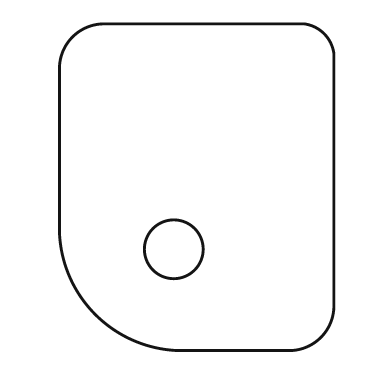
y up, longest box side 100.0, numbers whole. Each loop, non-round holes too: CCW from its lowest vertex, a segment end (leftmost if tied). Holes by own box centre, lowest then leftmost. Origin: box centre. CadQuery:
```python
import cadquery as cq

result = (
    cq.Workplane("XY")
    .moveTo(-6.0, -50.0)
    .lineTo(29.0, -50.0)
    .threePointArc((38.0, -46.0), (42.0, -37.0))
    .lineTo(42.0, 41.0)
    .threePointArc((39.0, 47.0), (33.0, 50.0))
    .lineTo(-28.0, 50.0)
    .threePointArc((-38.0, 46.0), (-42.0, 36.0))
    .lineTo(-42.0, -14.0)
    .threePointArc((-31.0, -39.0), (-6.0, -50.0))
    .close()
    .moveTo(-7.0, -19.0)
    .circle(9.0)
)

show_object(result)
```